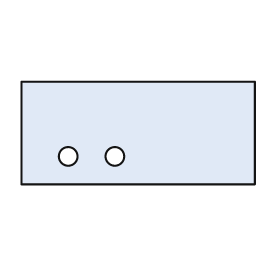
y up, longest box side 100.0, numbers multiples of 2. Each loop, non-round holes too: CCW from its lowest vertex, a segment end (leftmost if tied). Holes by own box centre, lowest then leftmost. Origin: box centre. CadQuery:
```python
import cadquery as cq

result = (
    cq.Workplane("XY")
    .moveTo(-50.0, -22.0)
    .lineTo(50.0, -22.0)
    .lineTo(50.0, 22.0)
    .lineTo(-50.0, 22.0)
    .close()
    .moveTo(-30.0, -10.0)
    .circle(4.0)
    .moveTo(-10.0, -10.0)
    .circle(4.0)
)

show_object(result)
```